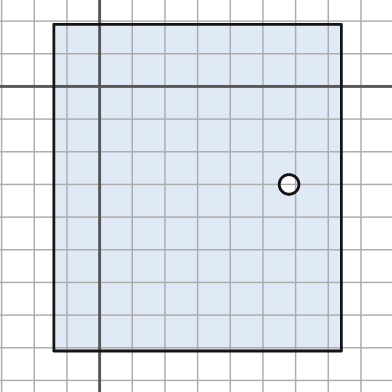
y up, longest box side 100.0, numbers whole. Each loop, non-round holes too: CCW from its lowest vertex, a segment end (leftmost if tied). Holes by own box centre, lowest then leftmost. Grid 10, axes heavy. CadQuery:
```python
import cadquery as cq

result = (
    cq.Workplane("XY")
    .moveTo(-14.0, -81.0)
    .lineTo(74.0, -81.0)
    .lineTo(74.0, 19.0)
    .lineTo(-14.0, 19.0)
    .close()
    .moveTo(58.0, -30.0)
    .circle(3.0)
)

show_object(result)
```